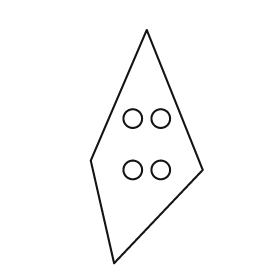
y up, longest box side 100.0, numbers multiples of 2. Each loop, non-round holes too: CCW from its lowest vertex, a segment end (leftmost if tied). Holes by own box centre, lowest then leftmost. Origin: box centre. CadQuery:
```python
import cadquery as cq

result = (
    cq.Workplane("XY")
    .moveTo(-14.0, -50.0)
    .lineTo(24.0, -10.0)
    .lineTo(0.0, 50.0)
    .lineTo(-24.0, -6.0)
    .close()
    .moveTo(-6.0, -10.0)
    .circle(4.0)
    .moveTo(6.0, -10.0)
    .circle(4.0)
    .moveTo(-6.0, 12.0)
    .circle(4.0)
    .moveTo(6.0, 12.0)
    .circle(4.0)
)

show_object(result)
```